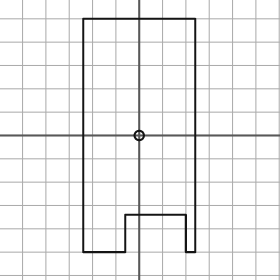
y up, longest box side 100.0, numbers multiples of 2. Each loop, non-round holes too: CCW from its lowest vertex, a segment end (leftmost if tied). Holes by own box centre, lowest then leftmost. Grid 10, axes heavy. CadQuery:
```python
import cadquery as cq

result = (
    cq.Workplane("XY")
    .moveTo(-24.0, -50.0)
    .lineTo(-6.0, -50.0)
    .lineTo(-6.0, -34.0)
    .lineTo(20.0, -34.0)
    .lineTo(20.0, -50.0)
    .lineTo(24.0, -50.0)
    .lineTo(24.0, 50.0)
    .lineTo(-24.0, 50.0)
    .close()
    .moveTo(0.0, 0.0)
    .circle(2.0)
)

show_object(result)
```